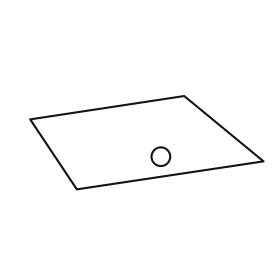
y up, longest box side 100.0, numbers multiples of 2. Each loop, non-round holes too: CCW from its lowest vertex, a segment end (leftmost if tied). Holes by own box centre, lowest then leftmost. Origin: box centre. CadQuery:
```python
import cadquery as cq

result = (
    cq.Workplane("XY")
    .moveTo(-30.0, -20.0)
    .lineTo(50.0, -8.0)
    .lineTo(16.0, 20.0)
    .lineTo(-50.0, 10.0)
    .close()
    .moveTo(6.0, -6.0)
    .circle(4.0)
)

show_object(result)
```